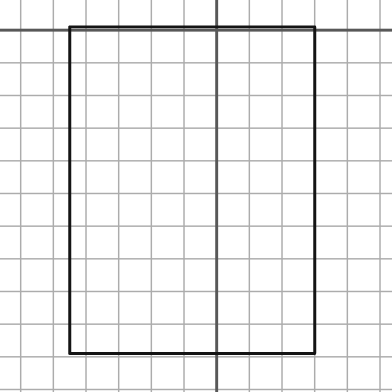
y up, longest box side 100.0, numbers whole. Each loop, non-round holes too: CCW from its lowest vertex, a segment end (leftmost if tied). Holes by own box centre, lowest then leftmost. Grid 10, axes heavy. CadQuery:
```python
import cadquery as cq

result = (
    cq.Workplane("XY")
    .moveTo(-45.0, -99.0)
    .lineTo(30.0, -99.0)
    .lineTo(30.0, 1.0)
    .lineTo(-45.0, 1.0)
    .close()
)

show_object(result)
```